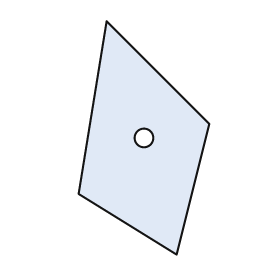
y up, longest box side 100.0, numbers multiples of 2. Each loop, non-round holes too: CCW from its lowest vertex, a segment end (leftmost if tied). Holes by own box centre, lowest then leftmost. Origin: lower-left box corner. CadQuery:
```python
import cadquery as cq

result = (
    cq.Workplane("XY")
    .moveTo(42.0, 0.0)
    .lineTo(56.0, 56.0)
    .lineTo(12.0, 100.0)
    .lineTo(0.0, 26.0)
    .close()
    .moveTo(28.0, 50.0)
    .circle(4.0)
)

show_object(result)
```